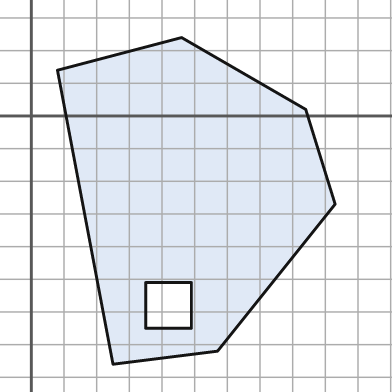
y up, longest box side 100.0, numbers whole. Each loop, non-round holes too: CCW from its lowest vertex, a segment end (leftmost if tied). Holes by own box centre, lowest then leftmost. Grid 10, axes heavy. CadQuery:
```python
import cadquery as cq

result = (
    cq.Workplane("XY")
    .moveTo(25.0, -76.0)
    .lineTo(57.0, -72.0)
    .lineTo(93.0, -27.0)
    .lineTo(84.0, 2.0)
    .lineTo(46.0, 24.0)
    .lineTo(8.0, 14.0)
    .close()
    .moveTo(35.0, -65.0)
    .lineTo(49.0, -65.0)
    .lineTo(49.0, -51.0)
    .lineTo(35.0, -51.0)
    .close()
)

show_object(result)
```